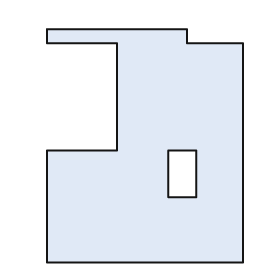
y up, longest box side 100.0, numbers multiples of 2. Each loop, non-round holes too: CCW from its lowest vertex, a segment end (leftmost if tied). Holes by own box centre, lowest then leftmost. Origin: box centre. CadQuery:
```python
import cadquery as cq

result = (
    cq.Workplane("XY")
    .moveTo(-42.0, -50.0)
    .lineTo(42.0, -50.0)
    .lineTo(42.0, 44.0)
    .lineTo(18.0, 44.0)
    .lineTo(18.0, 50.0)
    .lineTo(-42.0, 50.0)
    .lineTo(-42.0, 44.0)
    .lineTo(-12.0, 44.0)
    .lineTo(-12.0, -2.0)
    .lineTo(-42.0, -2.0)
    .close()
    .moveTo(10.0, -22.0)
    .lineTo(22.0, -22.0)
    .lineTo(22.0, -2.0)
    .lineTo(10.0, -2.0)
    .close()
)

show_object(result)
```